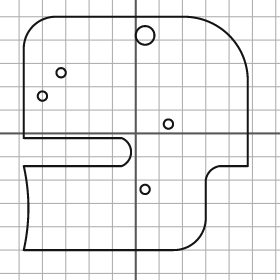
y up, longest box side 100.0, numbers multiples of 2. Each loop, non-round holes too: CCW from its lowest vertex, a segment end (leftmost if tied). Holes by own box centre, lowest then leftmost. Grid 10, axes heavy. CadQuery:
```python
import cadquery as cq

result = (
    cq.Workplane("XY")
    .moveTo(-48.0, -50.0)
    .lineTo(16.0, -50.0)
    .threePointArc((26.0, -46.0), (30.0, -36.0))
    .lineTo(30.0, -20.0)
    .threePointArc((32.0, -16.0), (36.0, -14.0))
    .lineTo(48.0, -14.0)
    .lineTo(48.0, 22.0)
    .threePointArc((40.0, 42.0), (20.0, 50.0))
    .lineTo(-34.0, 50.0)
    .threePointArc((-44.0, 46.0), (-48.0, 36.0))
    .lineTo(-48.0, -2.0)
    .lineTo(-6.0, -2.0)
    .threePointArc((-2.0, -8.0), (-6.0, -14.0))
    .lineTo(-48.0, -14.0)
    .threePointArc((-46.0, -32.0), (-48.0, -50.0))
    .close()
    .moveTo(4.0, -24.0)
    .circle(2.0)
    .moveTo(14.0, 4.0)
    .circle(2.0)
    .moveTo(-40.0, 16.0)
    .circle(2.0)
    .moveTo(-32.0, 26.0)
    .circle(2.0)
    .moveTo(4.0, 42.0)
    .circle(4.0)
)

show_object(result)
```